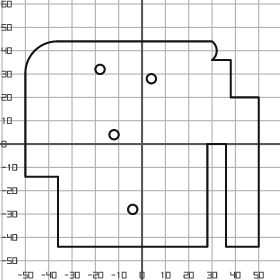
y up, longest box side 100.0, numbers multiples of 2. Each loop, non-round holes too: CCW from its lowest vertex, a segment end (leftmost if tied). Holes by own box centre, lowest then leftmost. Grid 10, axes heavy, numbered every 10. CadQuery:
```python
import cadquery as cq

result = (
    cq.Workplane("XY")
    .moveTo(-36.0, -44.0)
    .lineTo(28.0, -44.0)
    .lineTo(28.0, 0.0)
    .lineTo(36.0, 0.0)
    .lineTo(36.0, -44.0)
    .lineTo(50.0, -44.0)
    .lineTo(50.0, 20.0)
    .lineTo(38.0, 20.0)
    .lineTo(38.0, 36.0)
    .lineTo(30.0, 36.0)
    .threePointArc((32.0, 40.0), (30.0, 44.0))
    .lineTo(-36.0, 44.0)
    .threePointArc((-46.0, 40.0), (-50.0, 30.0))
    .lineTo(-50.0, -14.0)
    .lineTo(-36.0, -14.0)
    .close()
    .moveTo(-4.0, -28.0)
    .circle(2.0)
    .moveTo(-12.0, 4.0)
    .circle(2.0)
    .moveTo(4.0, 28.0)
    .circle(2.0)
    .moveTo(-18.0, 32.0)
    .circle(2.0)
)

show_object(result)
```